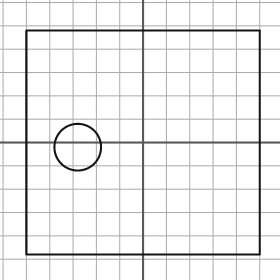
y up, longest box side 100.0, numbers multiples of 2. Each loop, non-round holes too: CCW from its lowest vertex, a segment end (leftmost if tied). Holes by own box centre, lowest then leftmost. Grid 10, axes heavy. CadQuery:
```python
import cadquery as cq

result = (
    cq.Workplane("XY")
    .moveTo(-50.0, -48.0)
    .lineTo(50.0, -48.0)
    .lineTo(50.0, 48.0)
    .lineTo(-50.0, 48.0)
    .close()
    .moveTo(-28.0, -2.0)
    .circle(10.0)
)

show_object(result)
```